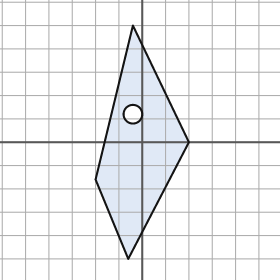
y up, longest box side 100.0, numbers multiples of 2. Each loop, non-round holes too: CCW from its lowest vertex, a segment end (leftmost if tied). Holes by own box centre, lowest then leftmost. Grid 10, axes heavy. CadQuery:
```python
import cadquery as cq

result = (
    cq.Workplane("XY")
    .moveTo(-6.0, -50.0)
    .lineTo(20.0, 0.0)
    .lineTo(-4.0, 50.0)
    .lineTo(-20.0, -16.0)
    .close()
    .moveTo(-4.0, 12.0)
    .circle(4.0)
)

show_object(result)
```